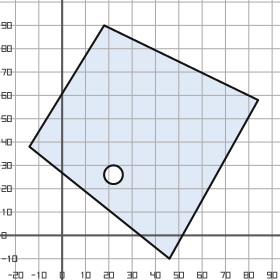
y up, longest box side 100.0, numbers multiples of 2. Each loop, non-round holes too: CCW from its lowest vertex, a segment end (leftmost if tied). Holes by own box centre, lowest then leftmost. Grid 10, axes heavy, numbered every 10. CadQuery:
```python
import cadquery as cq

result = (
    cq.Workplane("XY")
    .moveTo(46.0, -10.0)
    .lineTo(84.0, 58.0)
    .lineTo(18.0, 90.0)
    .lineTo(-14.0, 38.0)
    .close()
    .moveTo(22.0, 26.0)
    .circle(4.0)
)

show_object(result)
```